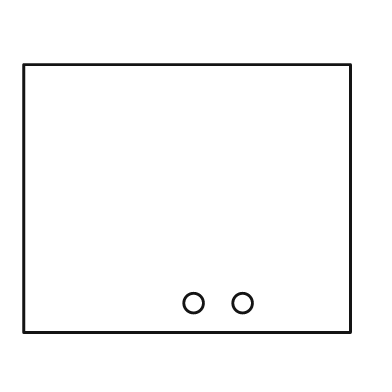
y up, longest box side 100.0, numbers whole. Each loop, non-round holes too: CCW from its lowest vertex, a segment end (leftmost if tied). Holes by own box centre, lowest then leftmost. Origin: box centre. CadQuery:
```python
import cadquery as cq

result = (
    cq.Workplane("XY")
    .moveTo(-50.0, -41.0)
    .lineTo(50.0, -41.0)
    .lineTo(50.0, 41.0)
    .lineTo(-50.0, 41.0)
    .close()
    .moveTo(2.0, -32.0)
    .circle(3.0)
    .moveTo(17.0, -32.0)
    .circle(3.0)
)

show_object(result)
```